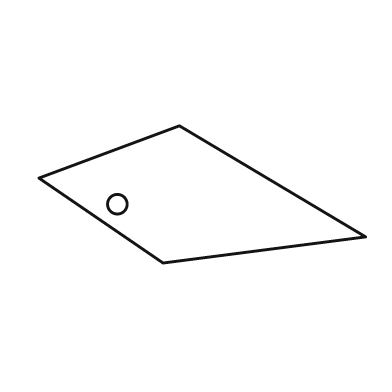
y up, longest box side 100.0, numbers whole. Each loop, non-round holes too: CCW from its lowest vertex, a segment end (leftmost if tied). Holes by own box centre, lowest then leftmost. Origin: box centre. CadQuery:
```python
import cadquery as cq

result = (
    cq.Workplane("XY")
    .moveTo(-12.0, -21.0)
    .lineTo(50.0, -13.0)
    .lineTo(-7.0, 21.0)
    .lineTo(-50.0, 5.0)
    .close()
    .moveTo(-26.0, -3.0)
    .circle(3.0)
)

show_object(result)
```